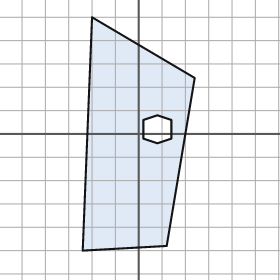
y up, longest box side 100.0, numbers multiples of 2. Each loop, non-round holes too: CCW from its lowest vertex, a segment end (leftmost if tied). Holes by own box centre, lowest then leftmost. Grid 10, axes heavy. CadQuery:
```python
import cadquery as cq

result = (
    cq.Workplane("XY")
    .moveTo(-24.0, -50.0)
    .lineTo(12.0, -48.0)
    .lineTo(24.0, 24.0)
    .lineTo(-20.0, 50.0)
    .close()
    .moveTo(8.0, -4.0)
    .lineTo(14.0, -2.0)
    .lineTo(14.0, 6.0)
    .lineTo(8.0, 8.0)
    .lineTo(2.0, 6.0)
    .lineTo(2.0, -2.0)
    .close()
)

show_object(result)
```